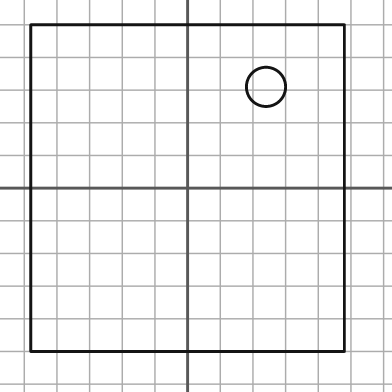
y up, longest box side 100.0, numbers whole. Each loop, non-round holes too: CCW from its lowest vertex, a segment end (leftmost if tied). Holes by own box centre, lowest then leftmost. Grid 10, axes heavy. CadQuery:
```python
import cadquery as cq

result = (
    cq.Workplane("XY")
    .moveTo(-48.0, -50.0)
    .lineTo(48.0, -50.0)
    .lineTo(48.0, 50.0)
    .lineTo(-48.0, 50.0)
    .close()
    .moveTo(24.0, 31.0)
    .circle(6.0)
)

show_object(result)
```